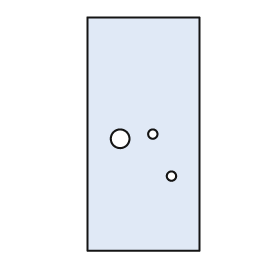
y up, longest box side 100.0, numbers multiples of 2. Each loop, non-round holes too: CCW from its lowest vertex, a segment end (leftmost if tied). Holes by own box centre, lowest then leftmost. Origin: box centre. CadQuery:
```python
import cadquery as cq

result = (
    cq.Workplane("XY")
    .moveTo(-24.0, -50.0)
    .lineTo(24.0, -50.0)
    .lineTo(24.0, 50.0)
    .lineTo(-24.0, 50.0)
    .close()
    .moveTo(12.0, -18.0)
    .circle(2.0)
    .moveTo(-10.0, -2.0)
    .circle(4.0)
    .moveTo(4.0, 0.0)
    .circle(2.0)
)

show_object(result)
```